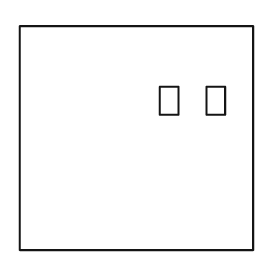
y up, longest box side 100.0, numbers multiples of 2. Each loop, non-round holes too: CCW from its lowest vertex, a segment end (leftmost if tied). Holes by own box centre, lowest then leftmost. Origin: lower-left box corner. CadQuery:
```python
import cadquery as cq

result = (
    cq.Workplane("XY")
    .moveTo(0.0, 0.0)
    .lineTo(100.0, 0.0)
    .lineTo(100.0, 96.0)
    .lineTo(0.0, 96.0)
    .close()
    .moveTo(60.0, 58.0)
    .lineTo(68.0, 58.0)
    .lineTo(68.0, 70.0)
    .lineTo(60.0, 70.0)
    .close()
    .moveTo(80.0, 58.0)
    .lineTo(88.0, 58.0)
    .lineTo(88.0, 70.0)
    .lineTo(80.0, 70.0)
    .close()
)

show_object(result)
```